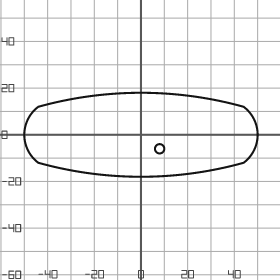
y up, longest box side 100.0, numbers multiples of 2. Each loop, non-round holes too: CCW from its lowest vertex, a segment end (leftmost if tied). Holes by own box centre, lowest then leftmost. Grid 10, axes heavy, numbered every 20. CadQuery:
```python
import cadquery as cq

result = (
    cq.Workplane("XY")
    .moveTo(-44.0, -12.0)
    .threePointArc((0.0, -18.0), (44.0, -12.0))
    .threePointArc((50.0, 0.0), (44.0, 12.0))
    .threePointArc((0.0, 18.0), (-44.0, 12.0))
    .threePointArc((-50.0, 0.0), (-44.0, -12.0))
    .close()
    .moveTo(8.0, -6.0)
    .circle(2.0)
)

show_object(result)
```